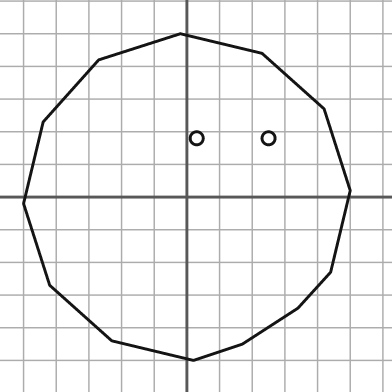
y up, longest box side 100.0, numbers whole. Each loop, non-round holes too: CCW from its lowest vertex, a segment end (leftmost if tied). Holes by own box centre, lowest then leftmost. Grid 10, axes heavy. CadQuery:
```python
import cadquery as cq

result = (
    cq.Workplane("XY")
    .moveTo(2.0, -50.0)
    .lineTo(17.0, -45.0)
    .lineTo(34.0, -34.0)
    .lineTo(44.0, -23.0)
    .lineTo(50.0, 2.0)
    .lineTo(42.0, 27.0)
    .lineTo(23.0, 44.0)
    .lineTo(-2.0, 50.0)
    .lineTo(-27.0, 42.0)
    .lineTo(-44.0, 23.0)
    .lineTo(-50.0, -2.0)
    .lineTo(-42.0, -27.0)
    .lineTo(-23.0, -44.0)
    .close()
    .moveTo(3.0, 18.0)
    .circle(2.0)
    .moveTo(25.0, 18.0)
    .circle(2.0)
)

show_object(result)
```